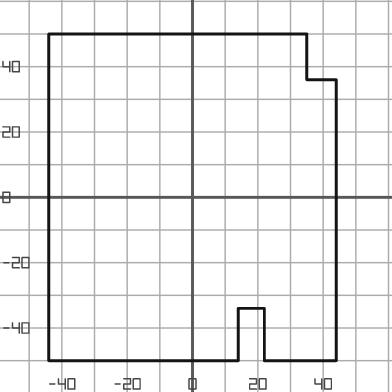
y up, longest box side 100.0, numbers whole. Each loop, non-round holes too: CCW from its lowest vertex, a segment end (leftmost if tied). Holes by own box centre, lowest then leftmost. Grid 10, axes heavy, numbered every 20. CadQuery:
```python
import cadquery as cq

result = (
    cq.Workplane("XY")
    .moveTo(-44.0, -50.0)
    .lineTo(14.0, -50.0)
    .lineTo(14.0, -34.0)
    .lineTo(22.0, -34.0)
    .lineTo(22.0, -50.0)
    .lineTo(44.0, -50.0)
    .lineTo(44.0, 36.0)
    .lineTo(35.0, 36.0)
    .lineTo(35.0, 50.0)
    .lineTo(-44.0, 50.0)
    .close()
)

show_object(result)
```